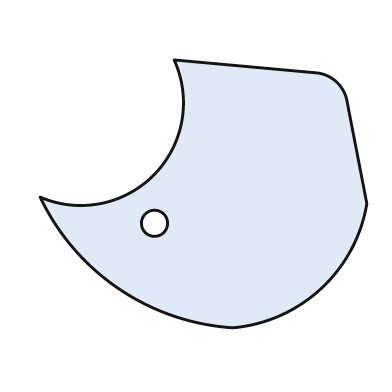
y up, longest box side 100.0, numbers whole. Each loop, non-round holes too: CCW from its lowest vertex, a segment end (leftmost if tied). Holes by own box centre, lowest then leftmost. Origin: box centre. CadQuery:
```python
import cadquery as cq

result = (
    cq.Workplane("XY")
    .moveTo(9.0, -41.0)
    .threePointArc((36.0, -29.0), (50.0, -3.0))
    .lineTo(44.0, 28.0)
    .threePointArc((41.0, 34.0), (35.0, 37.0))
    .lineTo(-9.0, 41.0)
    .threePointArc((-15.0, 6.0), (-50.0, -1.0))
    .threePointArc((-26.0, -29.0), (9.0, -41.0))
    .close()
    .moveTo(-15.0, -9.0)
    .circle(4.0)
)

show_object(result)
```